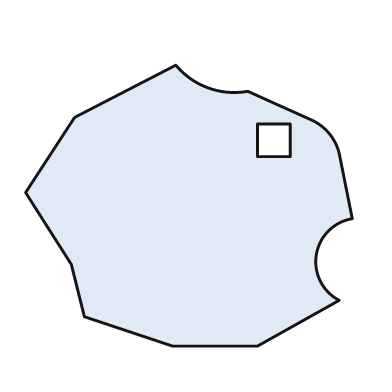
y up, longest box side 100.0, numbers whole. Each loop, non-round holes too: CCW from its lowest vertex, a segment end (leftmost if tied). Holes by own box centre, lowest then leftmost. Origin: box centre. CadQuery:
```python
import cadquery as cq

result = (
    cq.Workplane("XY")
    .moveTo(-5.0, -43.0)
    .lineTo(21.0, -43.0)
    .lineTo(46.0, -29.0)
    .threePointArc((39.0, -15.0), (50.0, -4.0))
    .lineTo(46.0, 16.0)
    .threePointArc((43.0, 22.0), (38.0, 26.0))
    .lineTo(18.0, 35.0)
    .threePointArc((6.0, 36.0), (-4.0, 43.0))
    .lineTo(-35.0, 27.0)
    .lineTo(-50.0, 4.0)
    .lineTo(-36.0, -18.0)
    .lineTo(-32.0, -34.0)
    .close()
    .moveTo(21.0, 15.0)
    .lineTo(31.0, 15.0)
    .lineTo(31.0, 25.0)
    .lineTo(21.0, 25.0)
    .close()
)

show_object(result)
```